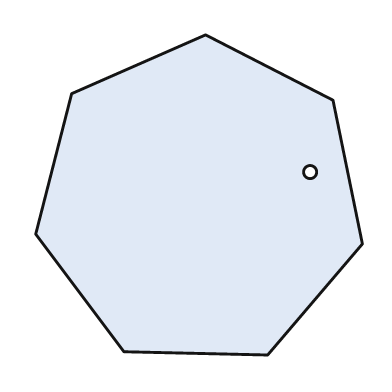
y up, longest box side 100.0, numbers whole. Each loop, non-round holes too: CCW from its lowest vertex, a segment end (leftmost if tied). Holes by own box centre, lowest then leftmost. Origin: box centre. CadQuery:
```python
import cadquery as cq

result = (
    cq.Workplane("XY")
    .moveTo(21.0, -49.0)
    .lineTo(50.0, -15.0)
    .lineTo(41.0, 29.0)
    .lineTo(2.0, 49.0)
    .lineTo(-39.0, 31.0)
    .lineTo(-50.0, -12.0)
    .lineTo(-23.0, -48.0)
    .close()
    .moveTo(34.0, 7.0)
    .circle(2.0)
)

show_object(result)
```